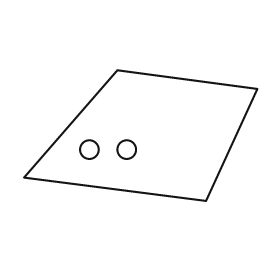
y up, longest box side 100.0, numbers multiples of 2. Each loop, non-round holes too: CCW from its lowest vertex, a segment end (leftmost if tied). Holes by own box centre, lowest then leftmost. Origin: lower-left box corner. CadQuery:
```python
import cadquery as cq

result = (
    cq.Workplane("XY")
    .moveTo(78.0, 0.0)
    .lineTo(100.0, 48.0)
    .lineTo(40.0, 56.0)
    .lineTo(0.0, 10.0)
    .close()
    .moveTo(28.0, 22.0)
    .circle(4.0)
    .moveTo(44.0, 22.0)
    .circle(4.0)
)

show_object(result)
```